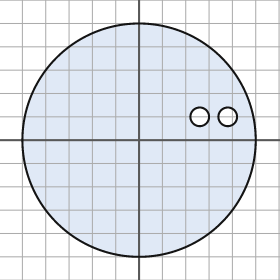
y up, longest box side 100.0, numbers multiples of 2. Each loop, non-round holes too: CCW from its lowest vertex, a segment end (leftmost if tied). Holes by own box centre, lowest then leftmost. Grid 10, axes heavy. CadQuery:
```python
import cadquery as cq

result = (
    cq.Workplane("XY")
    .moveTo(0.0, 0.0)
    .circle(50.0)
    .moveTo(26.0, 10.0)
    .circle(4.0)
    .moveTo(38.0, 10.0)
    .circle(4.0)
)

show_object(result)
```